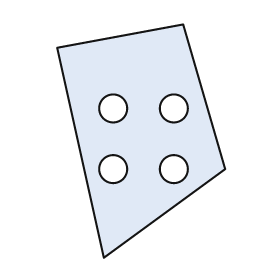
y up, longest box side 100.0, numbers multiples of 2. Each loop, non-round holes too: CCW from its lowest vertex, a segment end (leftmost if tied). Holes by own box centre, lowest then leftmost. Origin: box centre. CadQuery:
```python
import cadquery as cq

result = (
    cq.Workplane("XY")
    .moveTo(-16.0, -50.0)
    .lineTo(36.0, -12.0)
    .lineTo(18.0, 50.0)
    .lineTo(-36.0, 40.0)
    .close()
    .moveTo(-12.0, -12.0)
    .circle(6.0)
    .moveTo(14.0, -12.0)
    .circle(6.0)
    .moveTo(-12.0, 14.0)
    .circle(6.0)
    .moveTo(14.0, 14.0)
    .circle(6.0)
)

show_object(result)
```